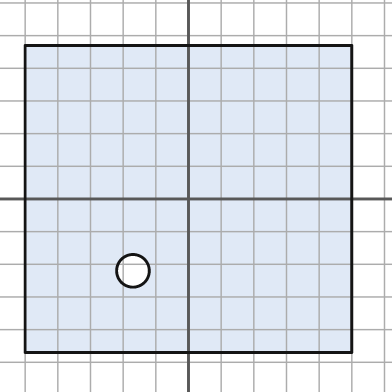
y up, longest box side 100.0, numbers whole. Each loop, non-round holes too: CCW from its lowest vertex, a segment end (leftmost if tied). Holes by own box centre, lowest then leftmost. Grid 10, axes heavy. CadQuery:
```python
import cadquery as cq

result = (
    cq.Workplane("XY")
    .moveTo(-50.0, -47.0)
    .lineTo(50.0, -47.0)
    .lineTo(50.0, 47.0)
    .lineTo(-50.0, 47.0)
    .close()
    .moveTo(-17.0, -22.0)
    .circle(5.0)
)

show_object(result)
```